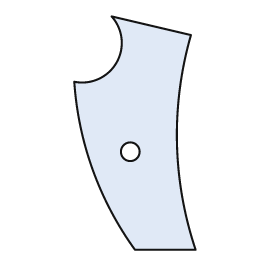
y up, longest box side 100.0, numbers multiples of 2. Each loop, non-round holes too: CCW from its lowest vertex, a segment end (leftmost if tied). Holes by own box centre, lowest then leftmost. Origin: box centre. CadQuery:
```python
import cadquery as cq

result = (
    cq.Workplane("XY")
    .moveTo(0.0, -50.0)
    .lineTo(26.0, -50.0)
    .threePointArc((18.0, -4.0), (24.0, 42.0))
    .lineTo(-10.0, 50.0)
    .threePointArc((-8.0, 30.0), (-26.0, 22.0))
    .threePointArc((-18.0, -16.0), (0.0, -50.0))
    .close()
    .moveTo(-2.0, -8.0)
    .circle(4.0)
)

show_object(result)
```